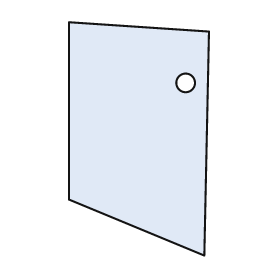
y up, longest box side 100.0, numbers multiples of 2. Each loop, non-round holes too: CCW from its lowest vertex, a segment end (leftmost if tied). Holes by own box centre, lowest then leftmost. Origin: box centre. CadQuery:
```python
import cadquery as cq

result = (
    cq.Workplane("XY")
    .moveTo(28.0, -50.0)
    .lineTo(30.0, 46.0)
    .lineTo(-30.0, 50.0)
    .lineTo(-30.0, -26.0)
    .close()
    .moveTo(20.0, 24.0)
    .circle(4.0)
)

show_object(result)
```